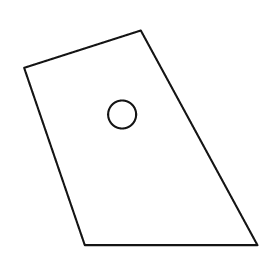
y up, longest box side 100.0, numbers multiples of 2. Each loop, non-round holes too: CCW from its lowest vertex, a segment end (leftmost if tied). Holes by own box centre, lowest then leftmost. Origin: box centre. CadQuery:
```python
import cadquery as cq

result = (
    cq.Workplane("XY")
    .moveTo(-24.0, -46.0)
    .lineTo(50.0, -46.0)
    .lineTo(0.0, 46.0)
    .lineTo(-50.0, 30.0)
    .close()
    .moveTo(-8.0, 10.0)
    .circle(6.0)
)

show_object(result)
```